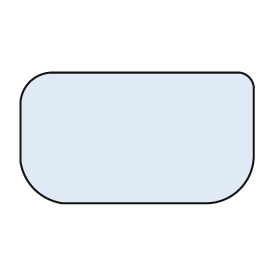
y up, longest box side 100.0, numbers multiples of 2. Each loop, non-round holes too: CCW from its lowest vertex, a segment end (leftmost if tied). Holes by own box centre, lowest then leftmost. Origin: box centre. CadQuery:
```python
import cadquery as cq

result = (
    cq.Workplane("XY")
    .moveTo(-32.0, -28.0)
    .lineTo(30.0, -28.0)
    .threePointArc((44.0, -22.0), (50.0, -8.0))
    .lineTo(50.0, 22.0)
    .threePointArc((48.0, 26.0), (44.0, 28.0))
    .lineTo(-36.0, 28.0)
    .threePointArc((-46.0, 24.0), (-50.0, 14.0))
    .lineTo(-50.0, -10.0)
    .threePointArc((-44.0, -22.0), (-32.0, -28.0))
    .close()
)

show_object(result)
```